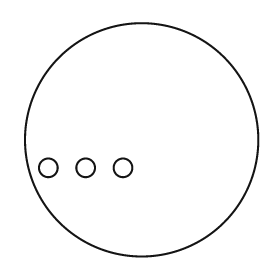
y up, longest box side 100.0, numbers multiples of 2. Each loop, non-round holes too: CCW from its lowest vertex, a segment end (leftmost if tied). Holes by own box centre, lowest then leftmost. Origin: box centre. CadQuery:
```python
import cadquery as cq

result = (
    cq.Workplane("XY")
    .moveTo(0.0, 0.0)
    .circle(50.0)
    .moveTo(-40.0, -12.0)
    .circle(4.0)
    .moveTo(-24.0, -12.0)
    .circle(4.0)
    .moveTo(-8.0, -12.0)
    .circle(4.0)
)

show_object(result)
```